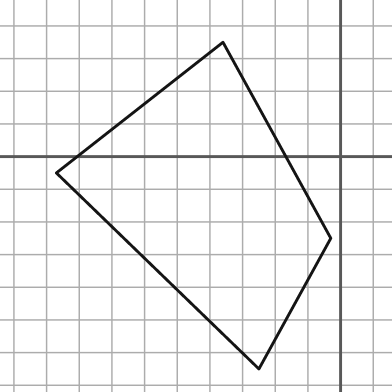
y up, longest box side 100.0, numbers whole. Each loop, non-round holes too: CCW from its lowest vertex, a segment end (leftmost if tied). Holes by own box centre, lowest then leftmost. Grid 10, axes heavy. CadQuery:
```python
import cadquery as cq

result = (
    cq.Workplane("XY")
    .moveTo(-25.0, -65.0)
    .lineTo(-3.0, -25.0)
    .lineTo(-36.0, 35.0)
    .lineTo(-87.0, -5.0)
    .close()
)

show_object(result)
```